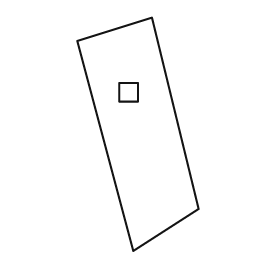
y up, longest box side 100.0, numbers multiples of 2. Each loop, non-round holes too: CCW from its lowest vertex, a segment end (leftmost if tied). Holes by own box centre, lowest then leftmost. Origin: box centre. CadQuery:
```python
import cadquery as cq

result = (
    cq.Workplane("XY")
    .moveTo(-2.0, -50.0)
    .lineTo(26.0, -32.0)
    .lineTo(6.0, 50.0)
    .lineTo(-26.0, 40.0)
    .close()
    .moveTo(-8.0, 14.0)
    .lineTo(0.0, 14.0)
    .lineTo(0.0, 22.0)
    .lineTo(-8.0, 22.0)
    .close()
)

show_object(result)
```